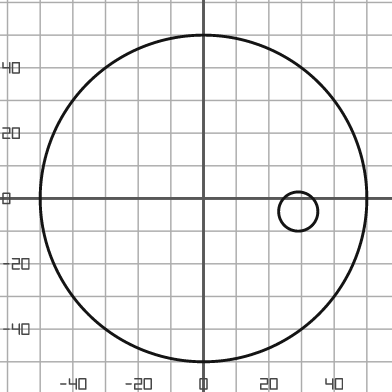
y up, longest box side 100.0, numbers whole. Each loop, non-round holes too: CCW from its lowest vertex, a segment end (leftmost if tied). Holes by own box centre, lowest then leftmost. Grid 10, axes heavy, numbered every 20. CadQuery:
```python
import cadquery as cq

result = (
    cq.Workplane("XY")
    .moveTo(0.0, 0.0)
    .circle(50.0)
    .moveTo(29.0, -4.0)
    .circle(6.0)
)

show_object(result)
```